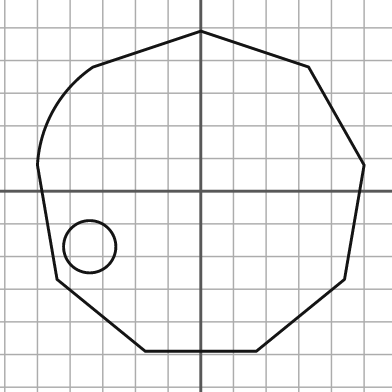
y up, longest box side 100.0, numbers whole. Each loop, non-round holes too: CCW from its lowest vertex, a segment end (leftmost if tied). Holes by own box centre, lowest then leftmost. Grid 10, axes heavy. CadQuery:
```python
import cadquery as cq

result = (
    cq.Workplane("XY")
    .moveTo(-17.0, -49.0)
    .lineTo(17.0, -49.0)
    .lineTo(44.0, -27.0)
    .lineTo(50.0, 8.0)
    .lineTo(33.0, 38.0)
    .lineTo(0.0, 49.0)
    .lineTo(-33.0, 38.0)
    .threePointArc((-45.0, 25.0), (-50.0, 8.0))
    .lineTo(-44.0, -27.0)
    .close()
    .moveTo(-34.0, -17.0)
    .circle(8.0)
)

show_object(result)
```